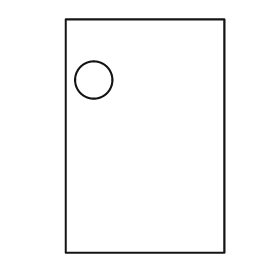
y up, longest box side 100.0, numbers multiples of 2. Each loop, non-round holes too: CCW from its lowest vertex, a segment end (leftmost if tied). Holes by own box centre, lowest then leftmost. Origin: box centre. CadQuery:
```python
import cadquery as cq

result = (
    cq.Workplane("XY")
    .moveTo(-34.0, -50.0)
    .lineTo(34.0, -50.0)
    .lineTo(34.0, 50.0)
    .lineTo(-34.0, 50.0)
    .close()
    .moveTo(-22.0, 24.0)
    .circle(8.0)
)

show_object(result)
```